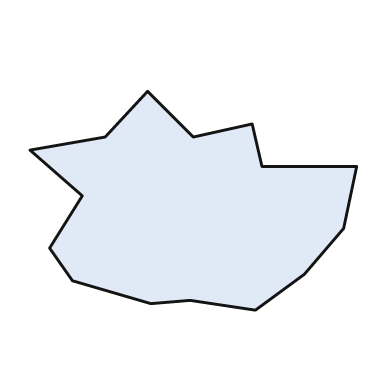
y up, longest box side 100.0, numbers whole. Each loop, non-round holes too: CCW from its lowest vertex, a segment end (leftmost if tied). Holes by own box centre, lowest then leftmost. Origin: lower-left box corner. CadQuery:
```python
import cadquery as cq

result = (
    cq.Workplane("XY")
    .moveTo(69.0, 0.0)
    .lineTo(84.0, 11.0)
    .lineTo(96.0, 25.0)
    .lineTo(100.0, 44.0)
    .lineTo(71.0, 44.0)
    .lineTo(68.0, 57.0)
    .lineTo(50.0, 53.0)
    .lineTo(36.0, 67.0)
    .lineTo(23.0, 53.0)
    .lineTo(0.0, 49.0)
    .lineTo(16.0, 35.0)
    .lineTo(6.0, 19.0)
    .lineTo(13.0, 9.0)
    .lineTo(37.0, 2.0)
    .lineTo(49.0, 3.0)
    .close()
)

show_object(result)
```